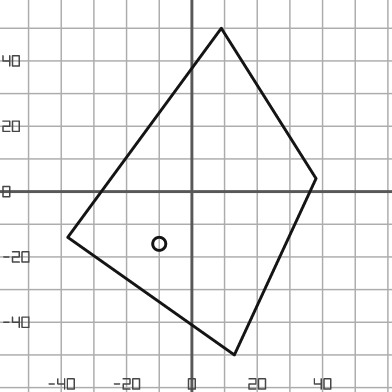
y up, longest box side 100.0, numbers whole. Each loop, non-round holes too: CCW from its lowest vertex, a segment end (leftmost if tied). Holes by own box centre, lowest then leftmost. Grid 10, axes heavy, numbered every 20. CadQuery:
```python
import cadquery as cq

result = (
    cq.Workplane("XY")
    .moveTo(13.0, -50.0)
    .lineTo(38.0, 4.0)
    .lineTo(9.0, 50.0)
    .lineTo(-38.0, -14.0)
    .close()
    .moveTo(-10.0, -16.0)
    .circle(2.0)
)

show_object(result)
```